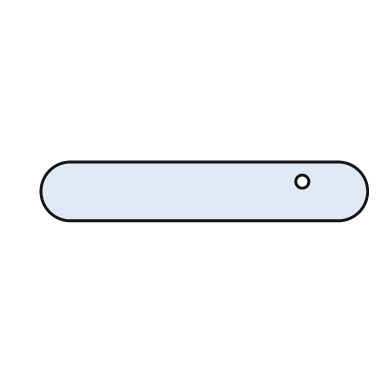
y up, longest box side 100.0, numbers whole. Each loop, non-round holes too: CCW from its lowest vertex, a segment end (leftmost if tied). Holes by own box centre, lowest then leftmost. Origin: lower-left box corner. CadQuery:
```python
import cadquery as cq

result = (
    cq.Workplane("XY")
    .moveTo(9.0, 0.0)
    .lineTo(91.0, 0.0)
    .threePointArc((100.0, 9.0), (91.0, 18.0))
    .lineTo(9.0, 18.0)
    .threePointArc((0.0, 9.0), (9.0, 0.0))
    .close()
    .moveTo(80.0, 12.0)
    .circle(2.0)
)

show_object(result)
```